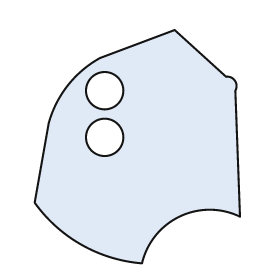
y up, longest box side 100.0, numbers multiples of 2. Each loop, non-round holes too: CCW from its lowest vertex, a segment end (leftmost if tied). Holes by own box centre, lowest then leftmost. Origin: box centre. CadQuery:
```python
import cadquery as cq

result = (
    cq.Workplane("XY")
    .moveTo(2.0, -50.0)
    .threePointArc((18.0, -30.0), (44.0, -30.0))
    .lineTo(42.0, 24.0)
    .threePointArc((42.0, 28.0), (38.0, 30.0))
    .lineTo(16.0, 50.0)
    .lineTo(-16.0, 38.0)
    .threePointArc((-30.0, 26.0), (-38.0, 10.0))
    .lineTo(-44.0, -24.0)
    .threePointArc((-24.0, -42.0), (2.0, -50.0))
    .close()
    .moveTo(-14.0, 4.0)
    .circle(8.0)
    .moveTo(-14.0, 24.0)
    .circle(8.0)
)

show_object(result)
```